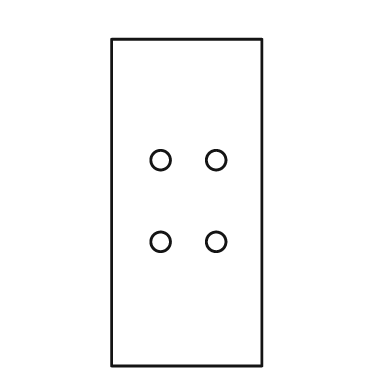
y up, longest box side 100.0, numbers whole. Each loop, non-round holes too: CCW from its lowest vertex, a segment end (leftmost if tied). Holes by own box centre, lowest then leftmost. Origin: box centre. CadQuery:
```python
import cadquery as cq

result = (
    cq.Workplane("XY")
    .moveTo(-23.0, -50.0)
    .lineTo(23.0, -50.0)
    .lineTo(23.0, 50.0)
    .lineTo(-23.0, 50.0)
    .close()
    .moveTo(-8.0, -12.0)
    .circle(3.0)
    .moveTo(9.0, -12.0)
    .circle(3.0)
    .moveTo(-8.0, 13.0)
    .circle(3.0)
    .moveTo(9.0, 13.0)
    .circle(3.0)
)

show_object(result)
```